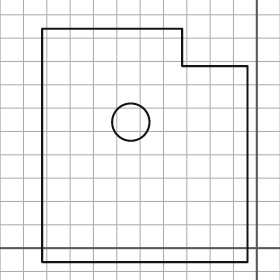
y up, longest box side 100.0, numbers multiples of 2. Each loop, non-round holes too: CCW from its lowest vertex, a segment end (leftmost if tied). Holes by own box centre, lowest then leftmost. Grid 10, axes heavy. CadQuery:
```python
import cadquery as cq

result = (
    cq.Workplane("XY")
    .moveTo(-92.0, -6.0)
    .lineTo(-4.0, -6.0)
    .lineTo(-4.0, 78.0)
    .lineTo(-32.0, 78.0)
    .lineTo(-32.0, 94.0)
    .lineTo(-92.0, 94.0)
    .close()
    .moveTo(-54.0, 54.0)
    .circle(8.0)
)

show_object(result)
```